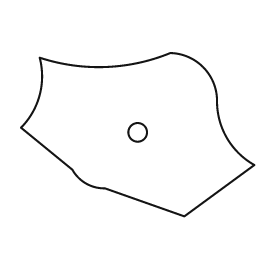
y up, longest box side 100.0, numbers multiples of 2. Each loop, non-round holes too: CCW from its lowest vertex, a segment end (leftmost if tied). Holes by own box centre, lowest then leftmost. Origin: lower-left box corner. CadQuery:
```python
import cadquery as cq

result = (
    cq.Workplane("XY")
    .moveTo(70.0, 0.0)
    .lineTo(100.0, 22.0)
    .threePointArc((88.0, 34.0), (84.0, 50.0))
    .threePointArc((78.0, 64.0), (64.0, 70.0))
    .threePointArc((36.0, 64.0), (8.0, 68.0))
    .threePointArc((8.0, 52.0), (0.0, 38.0))
    .lineTo(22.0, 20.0)
    .threePointArc((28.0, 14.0), (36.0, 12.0))
    .close()
    .moveTo(50.0, 36.0)
    .circle(4.0)
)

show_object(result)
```